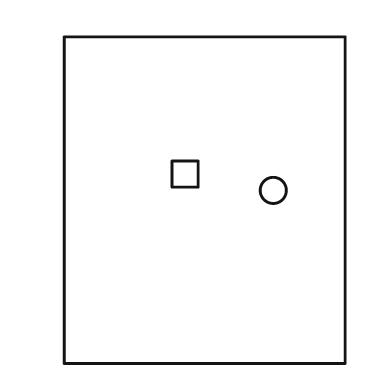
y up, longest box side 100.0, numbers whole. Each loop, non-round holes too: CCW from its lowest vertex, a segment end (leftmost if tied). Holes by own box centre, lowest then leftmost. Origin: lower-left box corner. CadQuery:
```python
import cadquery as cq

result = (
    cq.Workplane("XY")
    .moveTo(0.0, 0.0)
    .lineTo(86.0, 0.0)
    .lineTo(86.0, 100.0)
    .lineTo(0.0, 100.0)
    .close()
    .moveTo(64.0, 53.0)
    .circle(4.0)
    .moveTo(33.0, 54.0)
    .lineTo(41.0, 54.0)
    .lineTo(41.0, 62.0)
    .lineTo(33.0, 62.0)
    .close()
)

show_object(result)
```